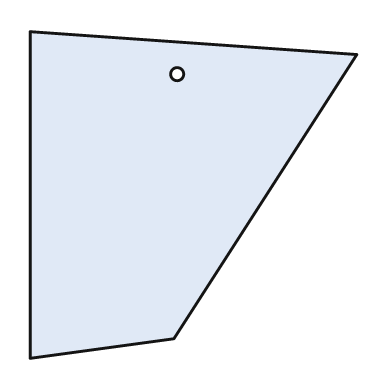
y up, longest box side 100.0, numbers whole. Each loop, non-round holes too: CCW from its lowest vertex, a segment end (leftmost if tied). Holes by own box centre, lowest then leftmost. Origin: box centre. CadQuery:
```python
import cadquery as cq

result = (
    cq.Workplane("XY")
    .moveTo(-50.0, -50.0)
    .lineTo(-6.0, -44.0)
    .lineTo(50.0, 43.0)
    .lineTo(-50.0, 50.0)
    .close()
    .moveTo(-5.0, 37.0)
    .circle(2.0)
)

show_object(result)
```